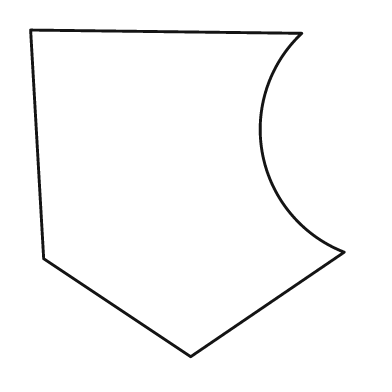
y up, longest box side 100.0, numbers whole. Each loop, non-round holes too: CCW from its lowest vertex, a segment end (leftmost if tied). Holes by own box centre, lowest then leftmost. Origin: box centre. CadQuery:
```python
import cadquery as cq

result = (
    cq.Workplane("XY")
    .moveTo(1.0, -50.0)
    .lineTo(48.0, -18.0)
    .threePointArc((23.0, 12.0), (35.0, 49.0))
    .lineTo(-48.0, 50.0)
    .lineTo(-44.0, -20.0)
    .close()
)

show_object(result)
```